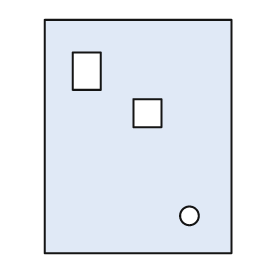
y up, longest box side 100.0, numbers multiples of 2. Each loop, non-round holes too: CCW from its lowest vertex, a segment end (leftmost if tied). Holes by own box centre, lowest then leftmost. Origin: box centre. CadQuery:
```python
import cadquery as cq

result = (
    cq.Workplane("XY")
    .moveTo(-40.0, -50.0)
    .lineTo(40.0, -50.0)
    .lineTo(40.0, 50.0)
    .lineTo(-40.0, 50.0)
    .close()
    .moveTo(22.0, -34.0)
    .circle(4.0)
    .moveTo(-2.0, 4.0)
    .lineTo(10.0, 4.0)
    .lineTo(10.0, 16.0)
    .lineTo(-2.0, 16.0)
    .close()
    .moveTo(-28.0, 20.0)
    .lineTo(-16.0, 20.0)
    .lineTo(-16.0, 36.0)
    .lineTo(-28.0, 36.0)
    .close()
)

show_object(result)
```